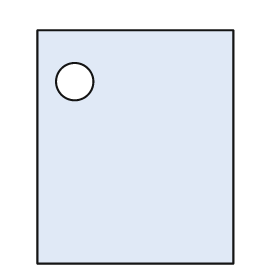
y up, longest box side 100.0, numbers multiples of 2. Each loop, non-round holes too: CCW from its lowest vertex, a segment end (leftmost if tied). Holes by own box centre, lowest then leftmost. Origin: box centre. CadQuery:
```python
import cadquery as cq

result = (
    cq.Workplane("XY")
    .moveTo(-42.0, -50.0)
    .lineTo(42.0, -50.0)
    .lineTo(42.0, 50.0)
    .lineTo(-42.0, 50.0)
    .close()
    .moveTo(-26.0, 28.0)
    .circle(8.0)
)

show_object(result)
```